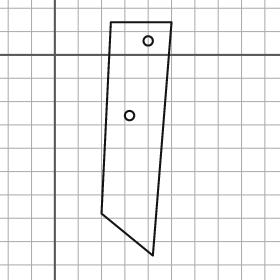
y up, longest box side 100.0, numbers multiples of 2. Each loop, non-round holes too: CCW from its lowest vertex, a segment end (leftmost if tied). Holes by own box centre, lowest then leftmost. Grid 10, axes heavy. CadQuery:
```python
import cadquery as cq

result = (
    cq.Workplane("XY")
    .moveTo(42.0, -86.0)
    .lineTo(50.0, 14.0)
    .lineTo(24.0, 14.0)
    .lineTo(20.0, -68.0)
    .close()
    .moveTo(32.0, -26.0)
    .circle(2.0)
    .moveTo(40.0, 6.0)
    .circle(2.0)
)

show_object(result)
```